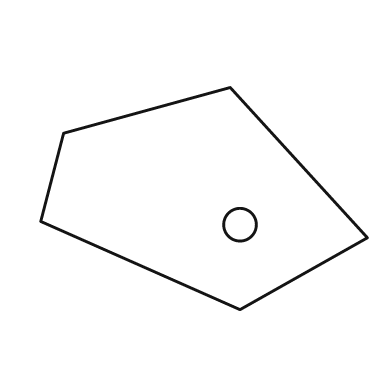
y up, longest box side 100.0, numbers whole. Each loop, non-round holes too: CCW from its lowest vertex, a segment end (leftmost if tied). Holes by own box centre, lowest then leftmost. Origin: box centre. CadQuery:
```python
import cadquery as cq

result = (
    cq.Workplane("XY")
    .moveTo(11.0, -34.0)
    .lineTo(50.0, -12.0)
    .lineTo(8.0, 34.0)
    .lineTo(-43.0, 20.0)
    .lineTo(-50.0, -7.0)
    .close()
    .moveTo(11.0, -8.0)
    .circle(5.0)
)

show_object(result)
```